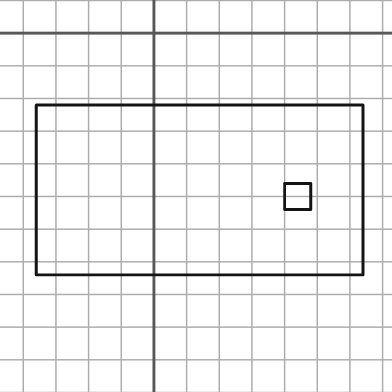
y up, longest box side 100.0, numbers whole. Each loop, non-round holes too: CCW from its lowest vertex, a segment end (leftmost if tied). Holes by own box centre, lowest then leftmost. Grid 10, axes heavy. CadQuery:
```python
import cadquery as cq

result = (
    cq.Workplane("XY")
    .moveTo(-36.0, -74.0)
    .lineTo(64.0, -74.0)
    .lineTo(64.0, -22.0)
    .lineTo(-36.0, -22.0)
    .close()
    .moveTo(40.0, -54.0)
    .lineTo(48.0, -54.0)
    .lineTo(48.0, -46.0)
    .lineTo(40.0, -46.0)
    .close()
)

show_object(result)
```